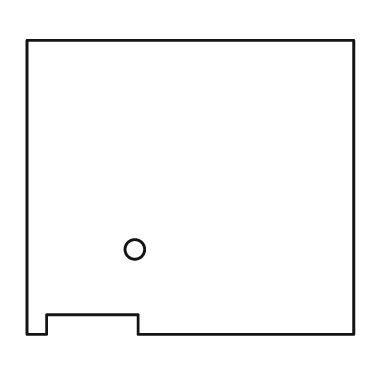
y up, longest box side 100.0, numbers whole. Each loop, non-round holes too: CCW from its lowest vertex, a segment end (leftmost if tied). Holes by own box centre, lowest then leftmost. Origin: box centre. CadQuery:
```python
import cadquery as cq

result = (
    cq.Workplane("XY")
    .moveTo(-50.0, -45.0)
    .lineTo(-44.0, -45.0)
    .lineTo(-44.0, -39.0)
    .lineTo(-16.0, -39.0)
    .lineTo(-16.0, -45.0)
    .lineTo(50.0, -45.0)
    .lineTo(50.0, 45.0)
    .lineTo(-50.0, 45.0)
    .close()
    .moveTo(-17.0, -19.0)
    .circle(3.0)
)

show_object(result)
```